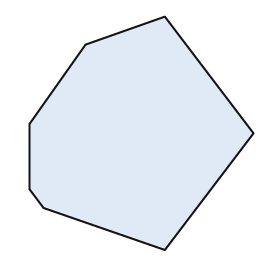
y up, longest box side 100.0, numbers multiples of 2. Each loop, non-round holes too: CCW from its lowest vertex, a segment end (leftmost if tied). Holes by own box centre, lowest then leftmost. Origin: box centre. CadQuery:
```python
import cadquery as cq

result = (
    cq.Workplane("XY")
    .moveTo(10.0, -50.0)
    .lineTo(48.0, 0.0)
    .lineTo(10.0, 50.0)
    .lineTo(-24.0, 38.0)
    .lineTo(-48.0, 4.0)
    .lineTo(-48.0, -24.0)
    .lineTo(-42.0, -32.0)
    .close()
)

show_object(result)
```